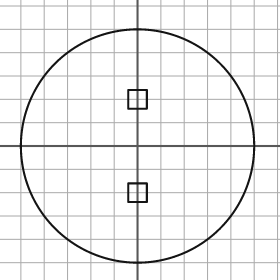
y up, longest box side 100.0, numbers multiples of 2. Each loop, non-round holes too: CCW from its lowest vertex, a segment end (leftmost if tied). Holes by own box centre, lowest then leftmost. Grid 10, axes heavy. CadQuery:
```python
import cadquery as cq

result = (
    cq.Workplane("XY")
    .moveTo(0.0, 0.0)
    .circle(50.0)
    .moveTo(-4.0, -24.0)
    .lineTo(4.0, -24.0)
    .lineTo(4.0, -16.0)
    .lineTo(-4.0, -16.0)
    .close()
    .moveTo(-4.0, 16.0)
    .lineTo(4.0, 16.0)
    .lineTo(4.0, 24.0)
    .lineTo(-4.0, 24.0)
    .close()
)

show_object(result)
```